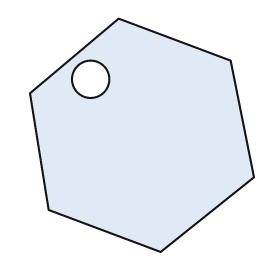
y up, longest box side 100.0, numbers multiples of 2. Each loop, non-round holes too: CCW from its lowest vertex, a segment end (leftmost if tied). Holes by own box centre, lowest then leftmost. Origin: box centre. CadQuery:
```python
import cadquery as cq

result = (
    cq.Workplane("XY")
    .moveTo(8.0, -50.0)
    .lineTo(48.0, -18.0)
    .lineTo(38.0, 32.0)
    .lineTo(-10.0, 50.0)
    .lineTo(-48.0, 18.0)
    .lineTo(-40.0, -32.0)
    .close()
    .moveTo(-22.0, 24.0)
    .circle(8.0)
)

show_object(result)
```